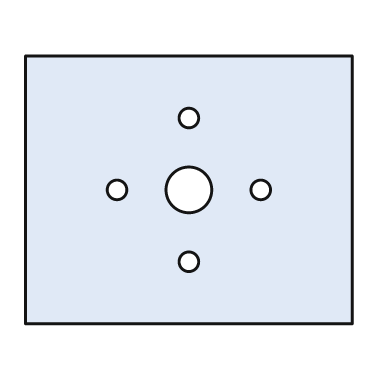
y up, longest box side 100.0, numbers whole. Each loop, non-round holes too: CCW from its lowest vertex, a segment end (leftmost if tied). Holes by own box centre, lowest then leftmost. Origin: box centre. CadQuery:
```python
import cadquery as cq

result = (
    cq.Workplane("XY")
    .moveTo(-50.0, -41.0)
    .lineTo(50.0, -41.0)
    .lineTo(50.0, 41.0)
    .lineTo(-50.0, 41.0)
    .close()
    .moveTo(0.0, -22.0)
    .circle(3.0)
    .moveTo(-22.0, 0.0)
    .circle(3.0)
    .moveTo(0.0, 0.0)
    .circle(7.0)
    .moveTo(22.0, 0.0)
    .circle(3.0)
    .moveTo(0.0, 22.0)
    .circle(3.0)
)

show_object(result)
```